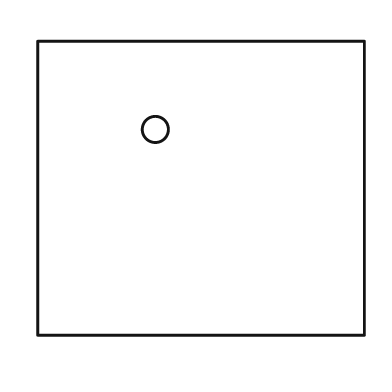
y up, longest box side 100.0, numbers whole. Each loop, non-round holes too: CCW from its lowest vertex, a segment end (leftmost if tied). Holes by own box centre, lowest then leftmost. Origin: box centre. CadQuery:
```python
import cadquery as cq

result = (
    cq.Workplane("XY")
    .moveTo(-50.0, -45.0)
    .lineTo(50.0, -45.0)
    .lineTo(50.0, 45.0)
    .lineTo(-50.0, 45.0)
    .close()
    .moveTo(-14.0, 18.0)
    .circle(4.0)
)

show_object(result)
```